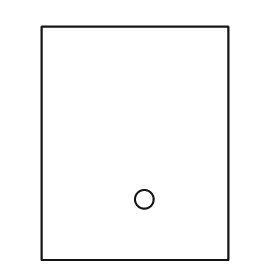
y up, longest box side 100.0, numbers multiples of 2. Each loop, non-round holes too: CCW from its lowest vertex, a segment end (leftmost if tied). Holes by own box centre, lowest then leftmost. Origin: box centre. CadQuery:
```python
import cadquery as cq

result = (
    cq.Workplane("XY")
    .moveTo(-40.0, -50.0)
    .lineTo(40.0, -50.0)
    .lineTo(40.0, 50.0)
    .lineTo(-40.0, 50.0)
    .close()
    .moveTo(4.0, -24.0)
    .circle(4.0)
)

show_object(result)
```